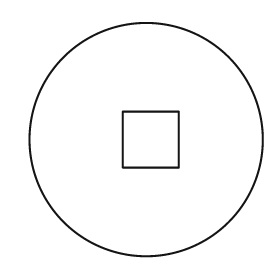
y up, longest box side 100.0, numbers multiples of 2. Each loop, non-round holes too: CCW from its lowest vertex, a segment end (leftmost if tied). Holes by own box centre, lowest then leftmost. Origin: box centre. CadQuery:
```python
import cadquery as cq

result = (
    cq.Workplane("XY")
    .moveTo(0.0, 0.0)
    .circle(50.0)
    .moveTo(-10.0, -12.0)
    .lineTo(14.0, -12.0)
    .lineTo(14.0, 12.0)
    .lineTo(-10.0, 12.0)
    .close()
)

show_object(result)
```